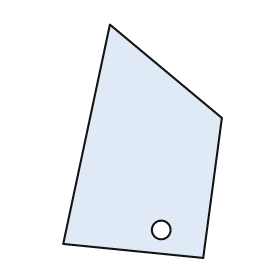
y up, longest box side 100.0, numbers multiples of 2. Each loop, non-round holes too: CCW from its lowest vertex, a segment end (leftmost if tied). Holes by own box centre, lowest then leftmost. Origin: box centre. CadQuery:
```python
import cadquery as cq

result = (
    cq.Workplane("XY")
    .moveTo(26.0, -50.0)
    .lineTo(34.0, 10.0)
    .lineTo(-14.0, 50.0)
    .lineTo(-34.0, -44.0)
    .close()
    .moveTo(8.0, -38.0)
    .circle(4.0)
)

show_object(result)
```